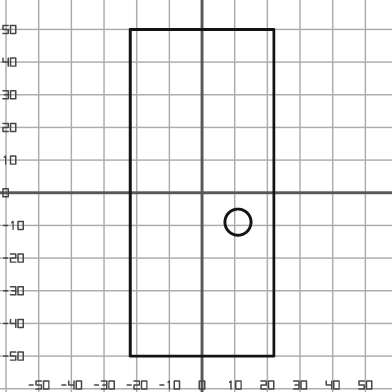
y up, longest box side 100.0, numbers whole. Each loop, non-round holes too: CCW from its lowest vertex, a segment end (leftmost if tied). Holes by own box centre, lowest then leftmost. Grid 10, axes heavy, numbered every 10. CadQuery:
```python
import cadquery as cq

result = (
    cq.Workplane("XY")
    .moveTo(-22.0, -50.0)
    .lineTo(22.0, -50.0)
    .lineTo(22.0, 50.0)
    .lineTo(-22.0, 50.0)
    .close()
    .moveTo(11.0, -9.0)
    .circle(4.0)
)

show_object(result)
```